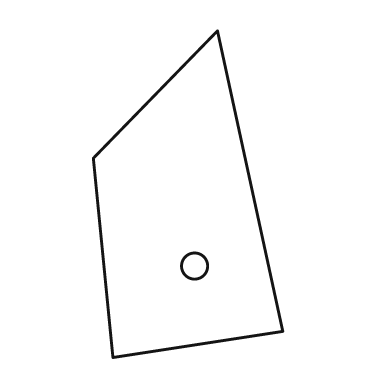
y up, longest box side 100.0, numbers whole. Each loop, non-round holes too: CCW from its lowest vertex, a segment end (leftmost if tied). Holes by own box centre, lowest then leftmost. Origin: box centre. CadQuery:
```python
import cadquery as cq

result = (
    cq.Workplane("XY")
    .moveTo(-23.0, -50.0)
    .lineTo(29.0, -42.0)
    .lineTo(9.0, 50.0)
    .lineTo(-29.0, 11.0)
    .close()
    .moveTo(2.0, -22.0)
    .circle(4.0)
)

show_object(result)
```